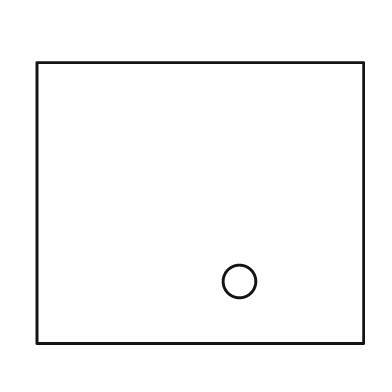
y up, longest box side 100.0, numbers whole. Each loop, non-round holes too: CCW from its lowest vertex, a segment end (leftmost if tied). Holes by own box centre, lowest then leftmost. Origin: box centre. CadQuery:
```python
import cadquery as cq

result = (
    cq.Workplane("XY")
    .moveTo(-50.0, -43.0)
    .lineTo(50.0, -43.0)
    .lineTo(50.0, 43.0)
    .lineTo(-50.0, 43.0)
    .close()
    .moveTo(12.0, -24.0)
    .circle(5.0)
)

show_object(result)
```